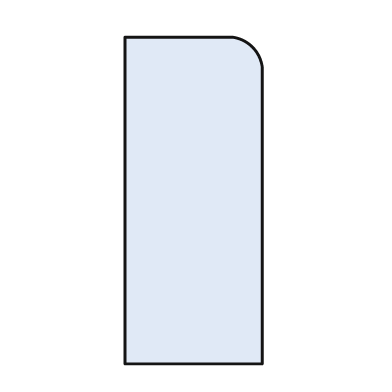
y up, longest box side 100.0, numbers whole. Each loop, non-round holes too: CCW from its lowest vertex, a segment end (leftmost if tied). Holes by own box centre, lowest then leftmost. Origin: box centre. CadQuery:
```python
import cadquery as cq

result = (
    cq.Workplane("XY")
    .moveTo(-21.0, -50.0)
    .lineTo(21.0, -50.0)
    .lineTo(21.0, 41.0)
    .threePointArc((18.0, 47.0), (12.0, 50.0))
    .lineTo(-21.0, 50.0)
    .close()
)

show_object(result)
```